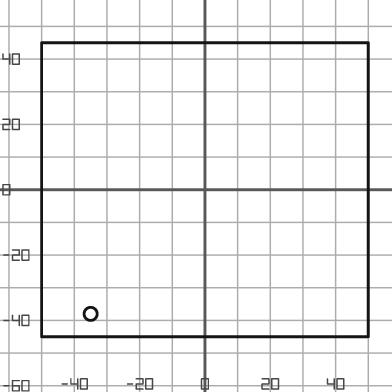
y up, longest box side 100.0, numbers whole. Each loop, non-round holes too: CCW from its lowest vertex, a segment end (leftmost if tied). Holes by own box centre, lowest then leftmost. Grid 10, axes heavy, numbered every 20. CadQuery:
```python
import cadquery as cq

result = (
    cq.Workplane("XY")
    .moveTo(-50.0, -45.0)
    .lineTo(50.0, -45.0)
    .lineTo(50.0, 45.0)
    .lineTo(-50.0, 45.0)
    .close()
    .moveTo(-35.0, -38.0)
    .circle(2.0)
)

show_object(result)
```